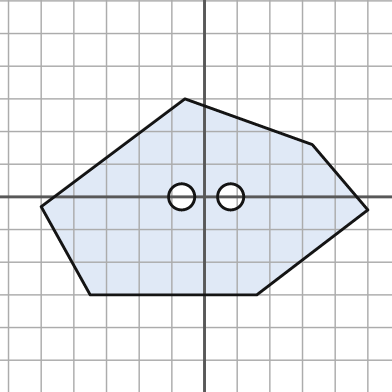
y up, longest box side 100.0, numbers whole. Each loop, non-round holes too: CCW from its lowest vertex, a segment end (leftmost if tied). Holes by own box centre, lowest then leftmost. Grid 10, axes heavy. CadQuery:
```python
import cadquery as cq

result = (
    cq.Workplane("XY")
    .moveTo(-35.0, -30.0)
    .lineTo(16.0, -30.0)
    .lineTo(50.0, -4.0)
    .lineTo(33.0, 16.0)
    .lineTo(-6.0, 30.0)
    .lineTo(-50.0, -3.0)
    .close()
    .moveTo(-7.0, 0.0)
    .circle(4.0)
    .moveTo(8.0, 0.0)
    .circle(4.0)
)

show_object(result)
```